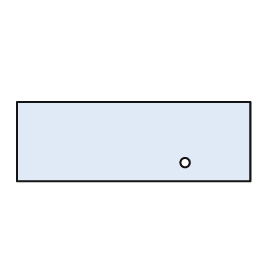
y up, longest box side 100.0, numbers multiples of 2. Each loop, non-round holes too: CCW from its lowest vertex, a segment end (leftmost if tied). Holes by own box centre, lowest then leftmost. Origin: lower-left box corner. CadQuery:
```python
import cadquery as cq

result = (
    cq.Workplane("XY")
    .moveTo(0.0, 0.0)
    .lineTo(100.0, 0.0)
    .lineTo(100.0, 34.0)
    .lineTo(0.0, 34.0)
    .close()
    .moveTo(72.0, 8.0)
    .circle(2.0)
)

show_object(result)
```